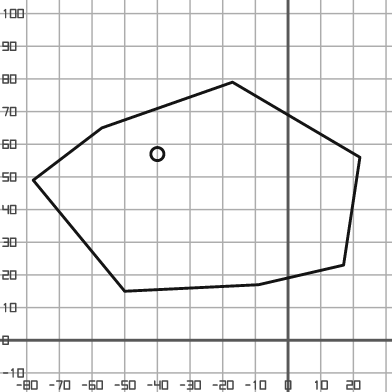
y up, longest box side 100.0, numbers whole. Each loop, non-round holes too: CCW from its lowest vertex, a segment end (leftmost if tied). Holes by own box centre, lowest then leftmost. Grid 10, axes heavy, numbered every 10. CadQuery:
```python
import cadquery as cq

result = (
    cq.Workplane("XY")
    .moveTo(-50.0, 15.0)
    .lineTo(-9.0, 17.0)
    .lineTo(17.0, 23.0)
    .lineTo(22.0, 56.0)
    .lineTo(-17.0, 79.0)
    .lineTo(-57.0, 65.0)
    .lineTo(-78.0, 49.0)
    .close()
    .moveTo(-40.0, 57.0)
    .circle(2.0)
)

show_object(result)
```